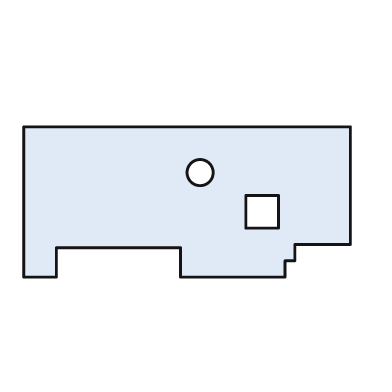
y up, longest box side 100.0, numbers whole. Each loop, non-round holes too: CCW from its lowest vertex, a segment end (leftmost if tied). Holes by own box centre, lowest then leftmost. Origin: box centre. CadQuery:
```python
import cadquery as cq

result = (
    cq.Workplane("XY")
    .moveTo(-50.0, -23.0)
    .lineTo(-40.0, -23.0)
    .lineTo(-40.0, -14.0)
    .lineTo(-2.0, -14.0)
    .lineTo(-2.0, -23.0)
    .lineTo(30.0, -23.0)
    .lineTo(30.0, -18.0)
    .lineTo(33.0, -18.0)
    .lineTo(33.0, -13.0)
    .lineTo(50.0, -13.0)
    .lineTo(50.0, 23.0)
    .lineTo(-50.0, 23.0)
    .close()
    .moveTo(18.0, -8.0)
    .lineTo(28.0, -8.0)
    .lineTo(28.0, 2.0)
    .lineTo(18.0, 2.0)
    .close()
    .moveTo(4.0, 9.0)
    .circle(4.0)
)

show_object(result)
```